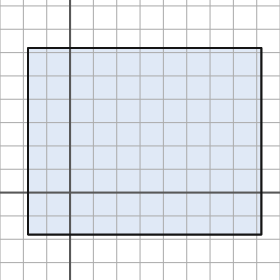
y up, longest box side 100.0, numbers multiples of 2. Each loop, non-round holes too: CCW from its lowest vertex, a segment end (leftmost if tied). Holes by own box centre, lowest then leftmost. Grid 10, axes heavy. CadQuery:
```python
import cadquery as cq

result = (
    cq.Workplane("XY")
    .moveTo(-18.0, -18.0)
    .lineTo(82.0, -18.0)
    .lineTo(82.0, 62.0)
    .lineTo(-18.0, 62.0)
    .close()
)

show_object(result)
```